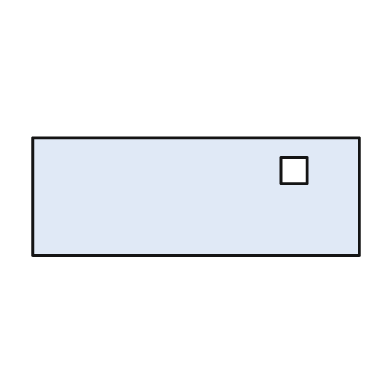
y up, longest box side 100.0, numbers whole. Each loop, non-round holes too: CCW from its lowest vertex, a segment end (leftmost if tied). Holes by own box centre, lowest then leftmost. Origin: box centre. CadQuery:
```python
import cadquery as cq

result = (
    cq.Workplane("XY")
    .moveTo(-50.0, -18.0)
    .lineTo(50.0, -18.0)
    .lineTo(50.0, 18.0)
    .lineTo(-50.0, 18.0)
    .close()
    .moveTo(26.0, 4.0)
    .lineTo(34.0, 4.0)
    .lineTo(34.0, 12.0)
    .lineTo(26.0, 12.0)
    .close()
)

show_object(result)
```